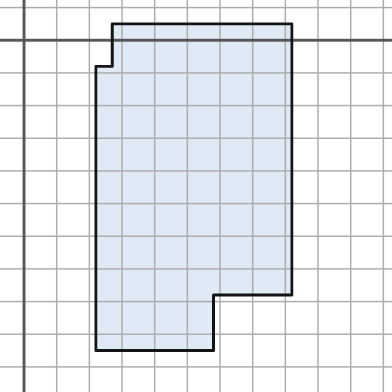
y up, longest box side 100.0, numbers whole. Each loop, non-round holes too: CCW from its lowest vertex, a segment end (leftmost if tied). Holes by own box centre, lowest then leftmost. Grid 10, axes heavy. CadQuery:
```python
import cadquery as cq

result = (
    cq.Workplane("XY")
    .moveTo(22.0, -95.0)
    .lineTo(58.0, -95.0)
    .lineTo(58.0, -78.0)
    .lineTo(82.0, -78.0)
    .lineTo(82.0, 5.0)
    .lineTo(27.0, 5.0)
    .lineTo(27.0, -8.0)
    .lineTo(22.0, -8.0)
    .close()
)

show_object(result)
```